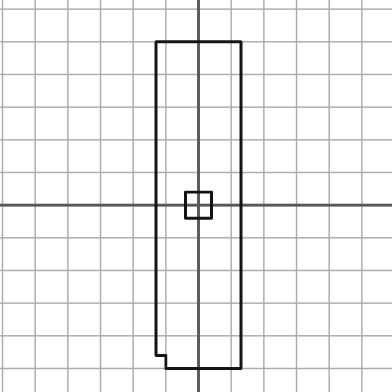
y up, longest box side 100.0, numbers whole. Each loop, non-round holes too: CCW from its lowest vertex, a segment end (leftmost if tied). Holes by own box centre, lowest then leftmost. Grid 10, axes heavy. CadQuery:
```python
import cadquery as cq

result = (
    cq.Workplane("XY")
    .moveTo(-10.0, -50.0)
    .lineTo(13.0, -50.0)
    .lineTo(13.0, 50.0)
    .lineTo(-13.0, 50.0)
    .lineTo(-13.0, -46.0)
    .lineTo(-10.0, -46.0)
    .close()
    .moveTo(-4.0, -4.0)
    .lineTo(4.0, -4.0)
    .lineTo(4.0, 4.0)
    .lineTo(-4.0, 4.0)
    .close()
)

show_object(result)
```